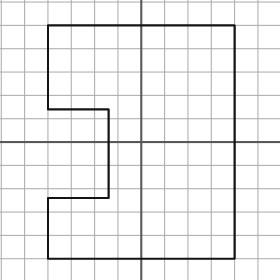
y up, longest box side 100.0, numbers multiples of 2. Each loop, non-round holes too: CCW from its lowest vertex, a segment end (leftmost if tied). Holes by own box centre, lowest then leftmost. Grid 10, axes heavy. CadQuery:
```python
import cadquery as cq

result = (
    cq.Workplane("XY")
    .moveTo(-40.0, -50.0)
    .lineTo(40.0, -50.0)
    .lineTo(40.0, 50.0)
    .lineTo(-40.0, 50.0)
    .lineTo(-40.0, 14.0)
    .lineTo(-14.0, 14.0)
    .lineTo(-14.0, -24.0)
    .lineTo(-40.0, -24.0)
    .close()
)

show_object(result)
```